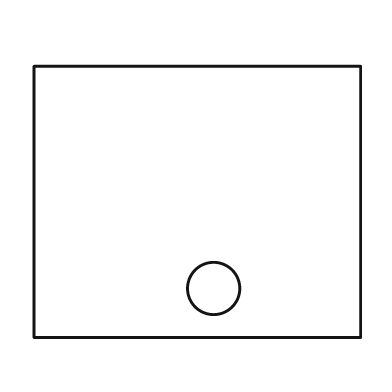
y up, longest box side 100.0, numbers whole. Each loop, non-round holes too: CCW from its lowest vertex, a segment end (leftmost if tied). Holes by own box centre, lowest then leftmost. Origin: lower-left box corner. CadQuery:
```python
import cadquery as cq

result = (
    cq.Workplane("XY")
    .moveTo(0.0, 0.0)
    .lineTo(100.0, 0.0)
    .lineTo(100.0, 83.0)
    .lineTo(0.0, 83.0)
    .close()
    .moveTo(55.0, 15.0)
    .circle(8.0)
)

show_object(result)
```